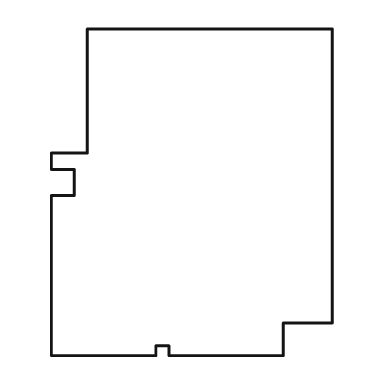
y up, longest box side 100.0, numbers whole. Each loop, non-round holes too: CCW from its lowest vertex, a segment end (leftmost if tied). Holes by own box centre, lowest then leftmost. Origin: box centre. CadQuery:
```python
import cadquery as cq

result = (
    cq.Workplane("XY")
    .moveTo(-43.0, -50.0)
    .lineTo(-11.0, -50.0)
    .lineTo(-11.0, -47.0)
    .lineTo(-7.0, -47.0)
    .lineTo(-7.0, -50.0)
    .lineTo(28.0, -50.0)
    .lineTo(28.0, -40.0)
    .lineTo(43.0, -40.0)
    .lineTo(43.0, 50.0)
    .lineTo(-32.0, 50.0)
    .lineTo(-32.0, 12.0)
    .lineTo(-43.0, 12.0)
    .lineTo(-43.0, 7.0)
    .lineTo(-36.0, 7.0)
    .lineTo(-36.0, -1.0)
    .lineTo(-43.0, -1.0)
    .close()
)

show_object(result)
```